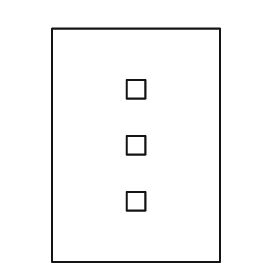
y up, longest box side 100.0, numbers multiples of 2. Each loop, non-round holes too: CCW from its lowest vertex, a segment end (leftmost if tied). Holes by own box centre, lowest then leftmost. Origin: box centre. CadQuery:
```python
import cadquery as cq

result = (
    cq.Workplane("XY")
    .moveTo(-36.0, -50.0)
    .lineTo(36.0, -50.0)
    .lineTo(36.0, 50.0)
    .lineTo(-36.0, 50.0)
    .close()
    .moveTo(-4.0, -28.0)
    .lineTo(4.0, -28.0)
    .lineTo(4.0, -20.0)
    .lineTo(-4.0, -20.0)
    .close()
    .moveTo(-4.0, -4.0)
    .lineTo(4.0, -4.0)
    .lineTo(4.0, 4.0)
    .lineTo(-4.0, 4.0)
    .close()
    .moveTo(-4.0, 20.0)
    .lineTo(4.0, 20.0)
    .lineTo(4.0, 28.0)
    .lineTo(-4.0, 28.0)
    .close()
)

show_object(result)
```